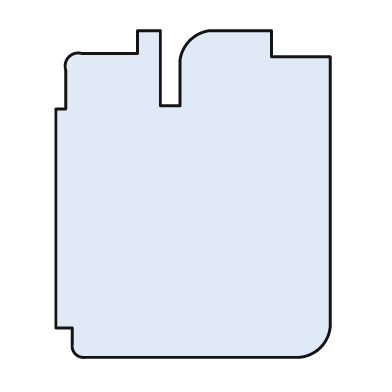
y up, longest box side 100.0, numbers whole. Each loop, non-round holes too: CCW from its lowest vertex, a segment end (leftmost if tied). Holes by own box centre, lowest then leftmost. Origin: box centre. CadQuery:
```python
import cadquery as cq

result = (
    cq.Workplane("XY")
    .moveTo(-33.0, -50.0)
    .lineTo(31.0, -50.0)
    .threePointArc((39.0, -47.0), (42.0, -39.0))
    .lineTo(42.0, 42.0)
    .lineTo(24.0, 42.0)
    .lineTo(24.0, 50.0)
    .lineTo(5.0, 50.0)
    .threePointArc((-1.0, 47.0), (-4.0, 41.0))
    .lineTo(-4.0, 27.0)
    .lineTo(-10.0, 27.0)
    .lineTo(-10.0, 50.0)
    .lineTo(-17.0, 50.0)
    .lineTo(-17.0, 43.0)
    .lineTo(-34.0, 43.0)
    .threePointArc((-38.0, 42.0), (-39.0, 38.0))
    .lineTo(-39.0, 26.0)
    .lineTo(-42.0, 26.0)
    .lineTo(-42.0, -41.0)
    .lineTo(-37.0, -41.0)
    .lineTo(-37.0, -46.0)
    .threePointArc((-36.0, -49.0), (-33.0, -50.0))
    .close()
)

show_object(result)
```